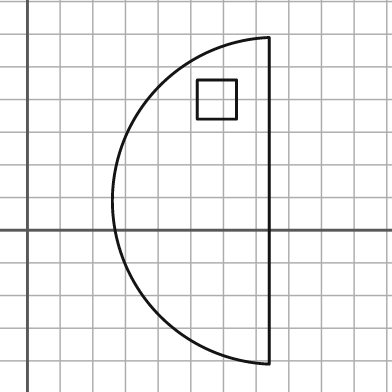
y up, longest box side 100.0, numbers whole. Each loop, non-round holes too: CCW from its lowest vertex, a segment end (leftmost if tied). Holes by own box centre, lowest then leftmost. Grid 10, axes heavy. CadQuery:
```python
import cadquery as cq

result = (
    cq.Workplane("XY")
    .moveTo(74.0, -41.0)
    .lineTo(74.0, 59.0)
    .threePointArc((26.0, 9.0), (74.0, -41.0))
    .close()
    .moveTo(52.0, 34.0)
    .lineTo(64.0, 34.0)
    .lineTo(64.0, 46.0)
    .lineTo(52.0, 46.0)
    .close()
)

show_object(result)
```